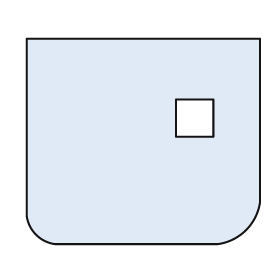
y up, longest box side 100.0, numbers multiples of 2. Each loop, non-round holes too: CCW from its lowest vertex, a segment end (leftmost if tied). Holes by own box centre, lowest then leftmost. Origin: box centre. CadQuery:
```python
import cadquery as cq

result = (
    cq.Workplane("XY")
    .moveTo(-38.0, -44.0)
    .lineTo(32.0, -44.0)
    .threePointArc((44.0, -38.0), (50.0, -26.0))
    .lineTo(50.0, 44.0)
    .lineTo(-50.0, 44.0)
    .lineTo(-50.0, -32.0)
    .threePointArc((-46.0, -40.0), (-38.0, -44.0))
    .close()
    .moveTo(14.0, 2.0)
    .lineTo(30.0, 2.0)
    .lineTo(30.0, 18.0)
    .lineTo(14.0, 18.0)
    .close()
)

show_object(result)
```